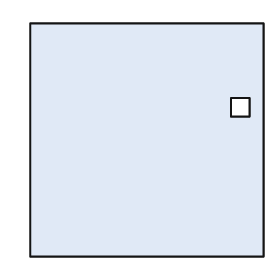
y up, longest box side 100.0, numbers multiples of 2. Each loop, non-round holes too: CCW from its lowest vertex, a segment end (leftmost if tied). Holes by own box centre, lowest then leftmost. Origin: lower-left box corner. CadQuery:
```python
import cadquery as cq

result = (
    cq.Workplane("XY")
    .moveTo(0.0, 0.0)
    .lineTo(100.0, 0.0)
    .lineTo(100.0, 100.0)
    .lineTo(0.0, 100.0)
    .close()
    .moveTo(86.0, 60.0)
    .lineTo(94.0, 60.0)
    .lineTo(94.0, 68.0)
    .lineTo(86.0, 68.0)
    .close()
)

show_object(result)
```